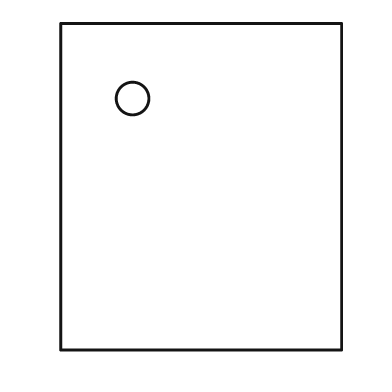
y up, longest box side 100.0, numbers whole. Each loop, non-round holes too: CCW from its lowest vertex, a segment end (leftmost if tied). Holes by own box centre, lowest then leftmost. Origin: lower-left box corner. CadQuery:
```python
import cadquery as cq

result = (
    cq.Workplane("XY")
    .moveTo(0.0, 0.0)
    .lineTo(86.0, 0.0)
    .lineTo(86.0, 100.0)
    .lineTo(0.0, 100.0)
    .close()
    .moveTo(22.0, 77.0)
    .circle(5.0)
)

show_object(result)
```